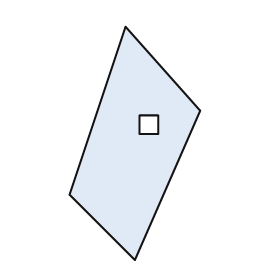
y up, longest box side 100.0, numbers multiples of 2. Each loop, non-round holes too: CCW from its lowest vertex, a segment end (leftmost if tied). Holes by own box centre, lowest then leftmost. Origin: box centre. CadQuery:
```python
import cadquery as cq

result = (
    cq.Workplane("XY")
    .moveTo(0.0, -50.0)
    .lineTo(28.0, 14.0)
    .lineTo(-4.0, 50.0)
    .lineTo(-28.0, -22.0)
    .close()
    .moveTo(2.0, 4.0)
    .lineTo(10.0, 4.0)
    .lineTo(10.0, 12.0)
    .lineTo(2.0, 12.0)
    .close()
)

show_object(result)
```